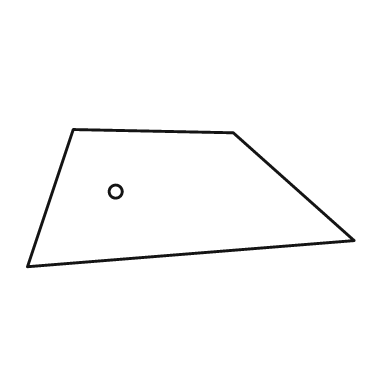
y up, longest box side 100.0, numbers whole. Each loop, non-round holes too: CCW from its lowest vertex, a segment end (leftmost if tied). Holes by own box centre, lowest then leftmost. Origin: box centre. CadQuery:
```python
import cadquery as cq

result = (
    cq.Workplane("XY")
    .moveTo(-50.0, -21.0)
    .lineTo(50.0, -13.0)
    .lineTo(13.0, 20.0)
    .lineTo(-36.0, 21.0)
    .close()
    .moveTo(-23.0, 2.0)
    .circle(2.0)
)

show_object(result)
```